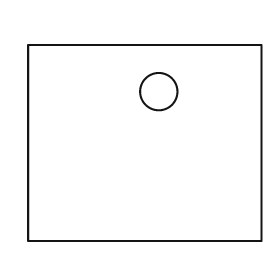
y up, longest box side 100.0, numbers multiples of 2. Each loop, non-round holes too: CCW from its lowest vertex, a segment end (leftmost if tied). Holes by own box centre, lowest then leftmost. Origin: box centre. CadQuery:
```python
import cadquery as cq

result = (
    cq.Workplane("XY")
    .moveTo(-50.0, -42.0)
    .lineTo(50.0, -42.0)
    .lineTo(50.0, 42.0)
    .lineTo(-50.0, 42.0)
    .close()
    .moveTo(6.0, 22.0)
    .circle(8.0)
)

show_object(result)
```